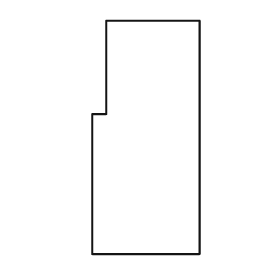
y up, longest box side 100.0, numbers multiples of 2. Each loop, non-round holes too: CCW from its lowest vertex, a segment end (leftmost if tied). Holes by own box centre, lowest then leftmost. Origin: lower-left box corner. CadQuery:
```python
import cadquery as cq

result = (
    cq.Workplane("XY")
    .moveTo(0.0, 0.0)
    .lineTo(46.0, 0.0)
    .lineTo(46.0, 100.0)
    .lineTo(6.0, 100.0)
    .lineTo(6.0, 60.0)
    .lineTo(0.0, 60.0)
    .close()
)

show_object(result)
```